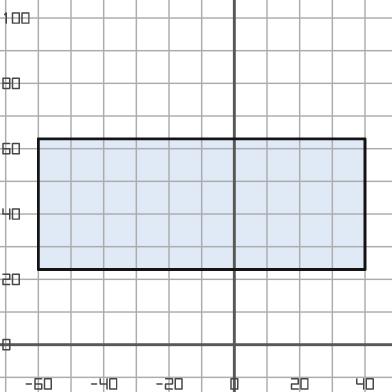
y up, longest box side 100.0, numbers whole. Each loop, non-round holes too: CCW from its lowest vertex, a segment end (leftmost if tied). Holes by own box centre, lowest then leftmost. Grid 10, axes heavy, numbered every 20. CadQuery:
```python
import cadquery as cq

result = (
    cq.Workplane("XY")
    .moveTo(-60.0, 23.0)
    .lineTo(40.0, 23.0)
    .lineTo(40.0, 63.0)
    .lineTo(-60.0, 63.0)
    .close()
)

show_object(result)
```